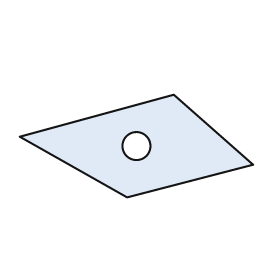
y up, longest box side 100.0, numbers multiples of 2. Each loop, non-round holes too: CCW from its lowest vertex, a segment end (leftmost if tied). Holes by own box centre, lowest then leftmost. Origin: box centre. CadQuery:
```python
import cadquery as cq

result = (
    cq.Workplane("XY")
    .moveTo(-4.0, -22.0)
    .lineTo(50.0, -8.0)
    .lineTo(16.0, 22.0)
    .lineTo(-50.0, 4.0)
    .close()
    .moveTo(0.0, 0.0)
    .circle(6.0)
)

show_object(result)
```